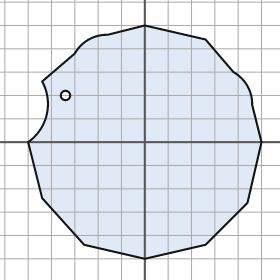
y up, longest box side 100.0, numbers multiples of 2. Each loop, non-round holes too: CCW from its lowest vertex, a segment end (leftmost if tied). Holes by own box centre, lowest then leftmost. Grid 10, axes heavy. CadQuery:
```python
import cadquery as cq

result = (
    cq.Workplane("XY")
    .moveTo(0.0, -50.0)
    .lineTo(26.0, -44.0)
    .lineTo(44.0, -26.0)
    .lineTo(50.0, 0.0)
    .lineTo(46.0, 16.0)
    .threePointArc((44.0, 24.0), (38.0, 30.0))
    .lineTo(26.0, 44.0)
    .lineTo(0.0, 50.0)
    .lineTo(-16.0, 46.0)
    .threePointArc((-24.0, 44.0), (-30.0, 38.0))
    .lineTo(-44.0, 26.0)
    .threePointArc((-42.0, 12.0), (-50.0, 0.0))
    .lineTo(-44.0, -24.0)
    .lineTo(-26.0, -44.0)
    .close()
    .moveTo(-34.0, 20.0)
    .circle(2.0)
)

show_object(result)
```